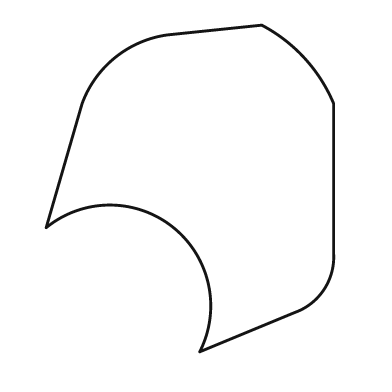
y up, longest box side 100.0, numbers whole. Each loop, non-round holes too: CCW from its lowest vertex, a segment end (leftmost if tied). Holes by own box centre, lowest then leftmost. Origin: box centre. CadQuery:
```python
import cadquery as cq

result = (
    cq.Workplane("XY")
    .moveTo(3.0, -50.0)
    .lineTo(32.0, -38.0)
    .threePointArc((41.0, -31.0), (44.0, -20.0))
    .lineTo(44.0, 26.0)
    .threePointArc((35.0, 40.0), (22.0, 50.0))
    .lineTo(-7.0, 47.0)
    .threePointArc((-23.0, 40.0), (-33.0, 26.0))
    .lineTo(-44.0, -12.0)
    .threePointArc((-5.0, -12.0), (3.0, -50.0))
    .close()
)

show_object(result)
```